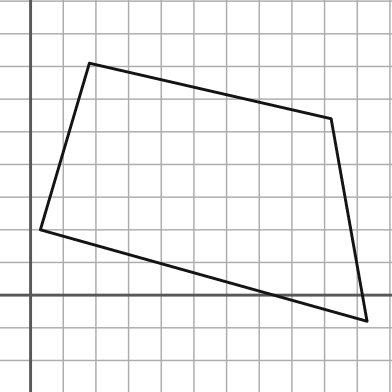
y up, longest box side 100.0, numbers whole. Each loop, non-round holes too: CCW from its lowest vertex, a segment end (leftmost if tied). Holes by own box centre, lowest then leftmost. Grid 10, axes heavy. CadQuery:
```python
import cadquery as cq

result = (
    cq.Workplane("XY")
    .moveTo(103.0, -8.0)
    .lineTo(92.0, 54.0)
    .lineTo(18.0, 71.0)
    .lineTo(3.0, 20.0)
    .close()
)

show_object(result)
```